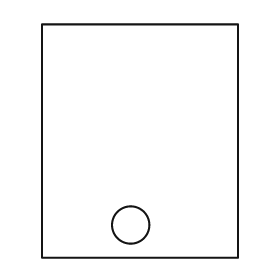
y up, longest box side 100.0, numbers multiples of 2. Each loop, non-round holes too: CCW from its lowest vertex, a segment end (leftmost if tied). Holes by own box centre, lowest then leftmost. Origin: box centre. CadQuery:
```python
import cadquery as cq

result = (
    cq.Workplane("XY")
    .moveTo(-42.0, -50.0)
    .lineTo(42.0, -50.0)
    .lineTo(42.0, 50.0)
    .lineTo(-42.0, 50.0)
    .close()
    .moveTo(-4.0, -36.0)
    .circle(8.0)
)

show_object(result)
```